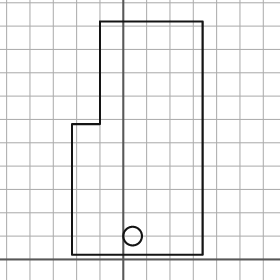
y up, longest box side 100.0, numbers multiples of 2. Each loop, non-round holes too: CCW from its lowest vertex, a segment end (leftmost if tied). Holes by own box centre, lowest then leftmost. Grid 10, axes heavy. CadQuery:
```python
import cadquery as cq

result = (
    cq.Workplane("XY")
    .moveTo(-22.0, 2.0)
    .lineTo(34.0, 2.0)
    .lineTo(34.0, 102.0)
    .lineTo(-10.0, 102.0)
    .lineTo(-10.0, 58.0)
    .lineTo(-22.0, 58.0)
    .close()
    .moveTo(4.0, 10.0)
    .circle(4.0)
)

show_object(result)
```